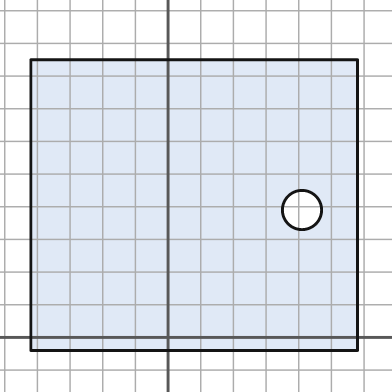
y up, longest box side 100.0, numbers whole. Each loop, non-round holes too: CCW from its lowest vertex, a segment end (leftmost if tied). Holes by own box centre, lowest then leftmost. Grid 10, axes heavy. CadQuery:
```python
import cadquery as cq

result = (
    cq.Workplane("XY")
    .moveTo(-42.0, -4.0)
    .lineTo(58.0, -4.0)
    .lineTo(58.0, 85.0)
    .lineTo(-42.0, 85.0)
    .close()
    .moveTo(41.0, 39.0)
    .circle(6.0)
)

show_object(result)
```